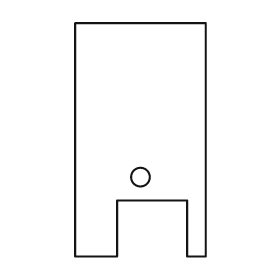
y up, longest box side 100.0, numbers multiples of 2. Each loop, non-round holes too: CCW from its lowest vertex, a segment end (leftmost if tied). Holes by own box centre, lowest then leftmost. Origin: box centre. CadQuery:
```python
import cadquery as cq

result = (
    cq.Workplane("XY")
    .moveTo(-28.0, -50.0)
    .lineTo(-10.0, -50.0)
    .lineTo(-10.0, -26.0)
    .lineTo(20.0, -26.0)
    .lineTo(20.0, -50.0)
    .lineTo(28.0, -50.0)
    .lineTo(28.0, 50.0)
    .lineTo(-28.0, 50.0)
    .close()
    .moveTo(0.0, -16.0)
    .circle(4.0)
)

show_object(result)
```